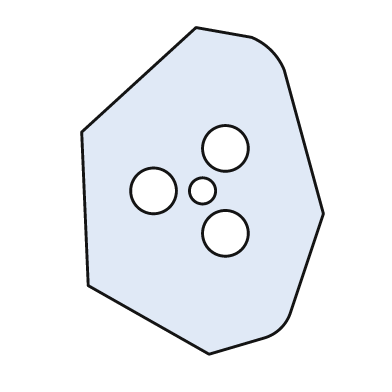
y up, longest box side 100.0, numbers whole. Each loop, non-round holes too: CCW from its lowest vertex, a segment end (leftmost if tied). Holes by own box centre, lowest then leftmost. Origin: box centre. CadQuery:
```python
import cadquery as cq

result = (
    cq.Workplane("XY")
    .moveTo(2.0, -50.0)
    .lineTo(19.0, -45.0)
    .threePointArc((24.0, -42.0), (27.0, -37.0))
    .lineTo(37.0, -7.0)
    .lineTo(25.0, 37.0)
    .threePointArc((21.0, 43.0), (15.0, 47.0))
    .lineTo(-2.0, 50.0)
    .lineTo(-37.0, 18.0)
    .lineTo(-35.0, -29.0)
    .close()
    .moveTo(7.0, -13.0)
    .circle(7.0)
    .moveTo(-15.0, 0.0)
    .circle(7.0)
    .moveTo(0.0, 0.0)
    .circle(4.0)
    .moveTo(7.0, 13.0)
    .circle(7.0)
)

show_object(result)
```